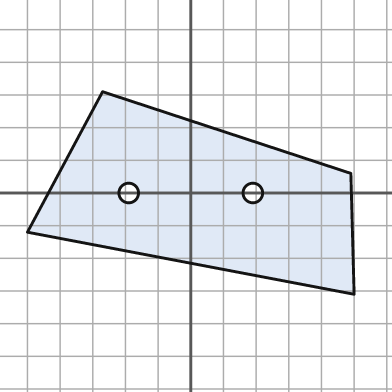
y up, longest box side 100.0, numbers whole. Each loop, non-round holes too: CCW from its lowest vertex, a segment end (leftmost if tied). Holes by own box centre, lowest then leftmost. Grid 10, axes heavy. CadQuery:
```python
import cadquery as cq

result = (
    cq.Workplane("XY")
    .moveTo(50.0, -31.0)
    .lineTo(49.0, 6.0)
    .lineTo(-27.0, 31.0)
    .lineTo(-50.0, -12.0)
    .close()
    .moveTo(-19.0, 0.0)
    .circle(3.0)
    .moveTo(19.0, 0.0)
    .circle(3.0)
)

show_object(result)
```